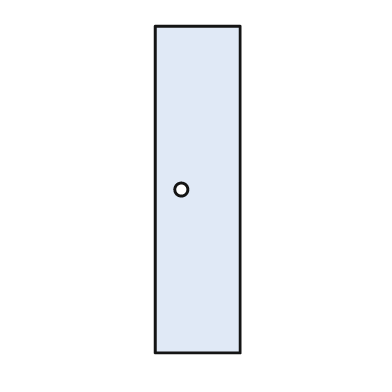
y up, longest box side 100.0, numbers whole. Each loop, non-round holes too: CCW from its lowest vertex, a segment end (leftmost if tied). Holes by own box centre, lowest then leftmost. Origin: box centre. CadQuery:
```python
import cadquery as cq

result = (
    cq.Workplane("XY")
    .moveTo(-13.0, -50.0)
    .lineTo(13.0, -50.0)
    .lineTo(13.0, 50.0)
    .lineTo(-13.0, 50.0)
    .close()
    .moveTo(-5.0, 0.0)
    .circle(2.0)
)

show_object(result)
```